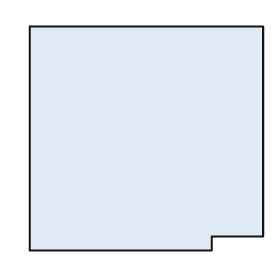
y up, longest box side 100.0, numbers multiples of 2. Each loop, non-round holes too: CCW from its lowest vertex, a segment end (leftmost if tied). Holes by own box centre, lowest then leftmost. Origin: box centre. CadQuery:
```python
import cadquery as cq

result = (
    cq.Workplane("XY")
    .moveTo(-50.0, -48.0)
    .lineTo(28.0, -48.0)
    .lineTo(28.0, -42.0)
    .lineTo(50.0, -42.0)
    .lineTo(50.0, 48.0)
    .lineTo(-50.0, 48.0)
    .close()
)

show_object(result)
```